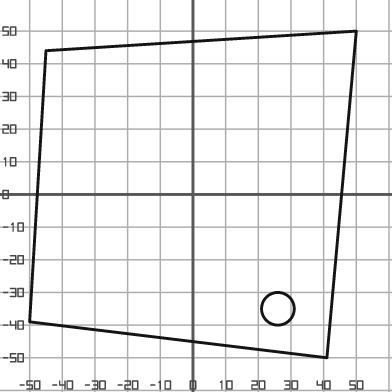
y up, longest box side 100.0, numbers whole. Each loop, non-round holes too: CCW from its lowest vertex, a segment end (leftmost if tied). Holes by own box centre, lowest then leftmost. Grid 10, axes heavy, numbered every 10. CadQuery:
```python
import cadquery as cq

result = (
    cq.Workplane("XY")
    .moveTo(41.0, -50.0)
    .lineTo(50.0, 50.0)
    .lineTo(-45.0, 44.0)
    .lineTo(-50.0, -39.0)
    .close()
    .moveTo(26.0, -35.0)
    .circle(5.0)
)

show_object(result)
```